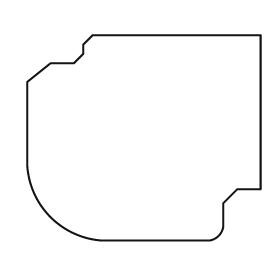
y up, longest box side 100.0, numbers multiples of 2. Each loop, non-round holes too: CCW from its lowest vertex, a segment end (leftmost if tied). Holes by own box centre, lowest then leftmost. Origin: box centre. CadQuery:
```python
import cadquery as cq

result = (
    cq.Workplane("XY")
    .moveTo(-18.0, -44.0)
    .lineTo(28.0, -44.0)
    .threePointArc((32.0, -42.0), (34.0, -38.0))
    .lineTo(34.0, -28.0)
    .lineTo(40.0, -22.0)
    .lineTo(50.0, -22.0)
    .lineTo(50.0, 44.0)
    .lineTo(-22.0, 44.0)
    .lineTo(-26.0, 40.0)
    .lineTo(-26.0, 36.0)
    .lineTo(-30.0, 32.0)
    .lineTo(-40.0, 32.0)
    .lineTo(-50.0, 24.0)
    .lineTo(-50.0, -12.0)
    .threePointArc((-40.0, -34.0), (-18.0, -44.0))
    .close()
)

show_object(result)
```